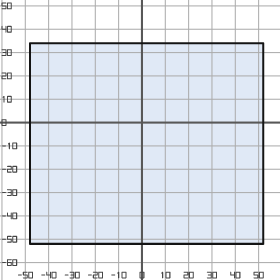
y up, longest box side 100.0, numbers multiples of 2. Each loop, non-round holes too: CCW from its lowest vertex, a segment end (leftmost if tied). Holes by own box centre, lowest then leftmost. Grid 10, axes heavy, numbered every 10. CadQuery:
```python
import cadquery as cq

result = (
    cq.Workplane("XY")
    .moveTo(-48.0, -52.0)
    .lineTo(52.0, -52.0)
    .lineTo(52.0, 34.0)
    .lineTo(-48.0, 34.0)
    .close()
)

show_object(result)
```